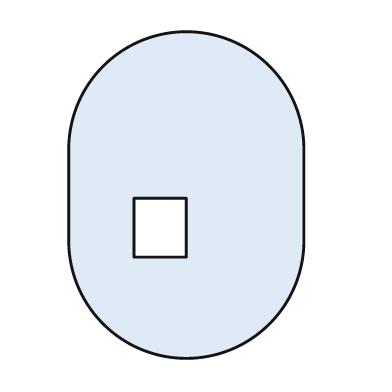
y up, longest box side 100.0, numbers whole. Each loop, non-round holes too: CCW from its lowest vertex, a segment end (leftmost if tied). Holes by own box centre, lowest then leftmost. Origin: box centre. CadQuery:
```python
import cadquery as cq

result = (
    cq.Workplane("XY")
    .moveTo(-36.0, -14.0)
    .threePointArc((0.0, -50.0), (36.0, -14.0))
    .lineTo(36.0, 14.0)
    .threePointArc((0.0, 50.0), (-36.0, 14.0))
    .close()
    .moveTo(-16.0, -19.0)
    .lineTo(0.0, -19.0)
    .lineTo(0.0, -1.0)
    .lineTo(-16.0, -1.0)
    .close()
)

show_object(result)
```